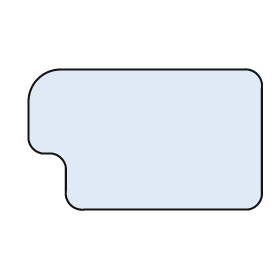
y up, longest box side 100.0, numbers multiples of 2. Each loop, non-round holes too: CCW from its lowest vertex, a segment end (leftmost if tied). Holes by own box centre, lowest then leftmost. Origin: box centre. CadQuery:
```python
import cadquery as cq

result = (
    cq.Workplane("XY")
    .moveTo(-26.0, -30.0)
    .lineTo(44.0, -30.0)
    .threePointArc((48.0, -28.0), (50.0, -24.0))
    .lineTo(50.0, 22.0)
    .threePointArc((48.0, 28.0), (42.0, 30.0))
    .lineTo(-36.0, 30.0)
    .threePointArc((-46.0, 26.0), (-50.0, 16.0))
    .lineTo(-50.0, 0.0)
    .threePointArc((-48.0, -4.0), (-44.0, -6.0))
    .lineTo(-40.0, -6.0)
    .threePointArc((-36.0, -8.0), (-34.0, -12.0))
    .lineTo(-34.0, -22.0)
    .threePointArc((-32.0, -28.0), (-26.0, -30.0))
    .close()
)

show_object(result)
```